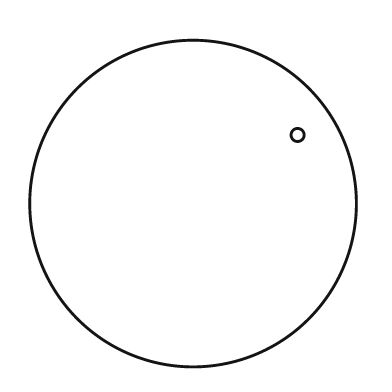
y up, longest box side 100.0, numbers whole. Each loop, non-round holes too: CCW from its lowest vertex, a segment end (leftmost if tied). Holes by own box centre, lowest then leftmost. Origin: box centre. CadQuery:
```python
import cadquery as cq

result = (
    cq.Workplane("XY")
    .moveTo(0.0, 0.0)
    .circle(50.0)
    .moveTo(32.0, 21.0)
    .circle(2.0)
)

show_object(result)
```